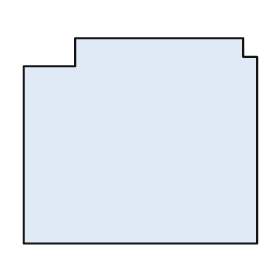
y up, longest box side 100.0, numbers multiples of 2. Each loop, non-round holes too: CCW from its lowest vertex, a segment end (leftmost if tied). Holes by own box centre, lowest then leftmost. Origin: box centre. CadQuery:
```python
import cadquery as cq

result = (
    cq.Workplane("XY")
    .moveTo(-50.0, -44.0)
    .lineTo(50.0, -44.0)
    .lineTo(50.0, 36.0)
    .lineTo(44.0, 36.0)
    .lineTo(44.0, 44.0)
    .lineTo(-28.0, 44.0)
    .lineTo(-28.0, 32.0)
    .lineTo(-50.0, 32.0)
    .close()
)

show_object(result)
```